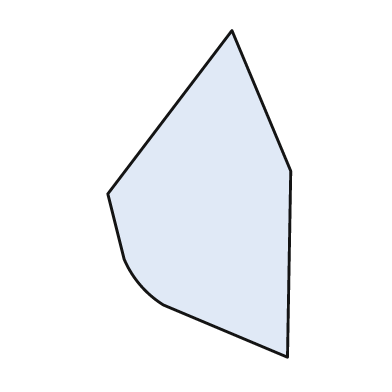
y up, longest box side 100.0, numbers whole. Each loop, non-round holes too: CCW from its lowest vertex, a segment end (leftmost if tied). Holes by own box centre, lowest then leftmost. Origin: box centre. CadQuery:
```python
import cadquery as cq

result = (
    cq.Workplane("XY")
    .moveTo(27.0, -50.0)
    .lineTo(28.0, 7.0)
    .lineTo(10.0, 50.0)
    .lineTo(-28.0, 0.0)
    .lineTo(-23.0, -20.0)
    .threePointArc((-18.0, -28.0), (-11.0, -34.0))
    .close()
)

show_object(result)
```